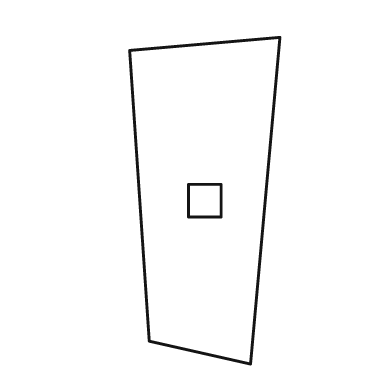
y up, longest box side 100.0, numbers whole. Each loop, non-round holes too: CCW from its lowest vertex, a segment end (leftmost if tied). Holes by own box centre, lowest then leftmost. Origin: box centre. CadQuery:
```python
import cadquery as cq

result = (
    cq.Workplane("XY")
    .moveTo(14.0, -50.0)
    .lineTo(23.0, 50.0)
    .lineTo(-23.0, 46.0)
    .lineTo(-17.0, -43.0)
    .close()
    .moveTo(-5.0, -5.0)
    .lineTo(5.0, -5.0)
    .lineTo(5.0, 5.0)
    .lineTo(-5.0, 5.0)
    .close()
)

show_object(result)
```